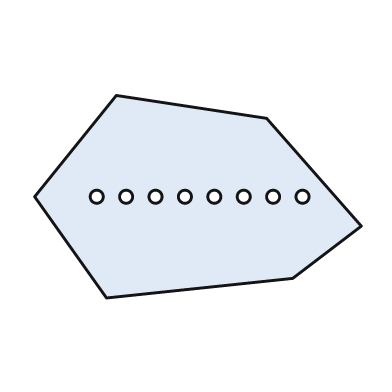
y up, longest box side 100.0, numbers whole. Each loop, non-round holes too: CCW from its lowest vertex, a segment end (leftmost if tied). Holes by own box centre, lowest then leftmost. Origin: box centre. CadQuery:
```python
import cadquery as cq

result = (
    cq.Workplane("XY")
    .moveTo(-28.0, -31.0)
    .lineTo(29.0, -25.0)
    .lineTo(50.0, -9.0)
    .lineTo(21.0, 24.0)
    .lineTo(-25.0, 31.0)
    .lineTo(-50.0, 0.0)
    .close()
    .moveTo(-31.0, 0.0)
    .circle(2.0)
    .moveTo(-22.0, 0.0)
    .circle(2.0)
    .moveTo(-13.0, 0.0)
    .circle(2.0)
    .moveTo(-4.0, 0.0)
    .circle(2.0)
    .moveTo(5.0, 0.0)
    .circle(2.0)
    .moveTo(14.0, 0.0)
    .circle(2.0)
    .moveTo(23.0, 0.0)
    .circle(2.0)
    .moveTo(32.0, 0.0)
    .circle(2.0)
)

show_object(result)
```